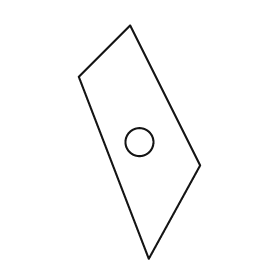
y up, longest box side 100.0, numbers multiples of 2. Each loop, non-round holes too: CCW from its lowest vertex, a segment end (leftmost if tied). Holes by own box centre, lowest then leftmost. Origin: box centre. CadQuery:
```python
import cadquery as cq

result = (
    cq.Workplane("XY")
    .moveTo(4.0, -50.0)
    .lineTo(26.0, -10.0)
    .lineTo(-4.0, 50.0)
    .lineTo(-26.0, 28.0)
    .close()
    .moveTo(0.0, 0.0)
    .circle(6.0)
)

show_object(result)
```